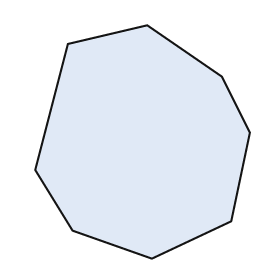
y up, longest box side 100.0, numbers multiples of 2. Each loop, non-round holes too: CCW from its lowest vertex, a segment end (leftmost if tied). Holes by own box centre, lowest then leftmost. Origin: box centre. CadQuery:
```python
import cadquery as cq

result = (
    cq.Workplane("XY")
    .moveTo(4.0, -50.0)
    .lineTo(38.0, -34.0)
    .lineTo(46.0, 4.0)
    .lineTo(34.0, 28.0)
    .lineTo(2.0, 50.0)
    .lineTo(-32.0, 42.0)
    .lineTo(-46.0, -12.0)
    .lineTo(-30.0, -38.0)
    .close()
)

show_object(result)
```